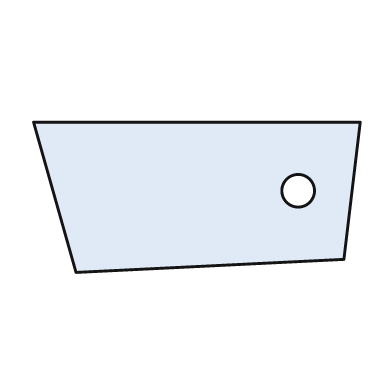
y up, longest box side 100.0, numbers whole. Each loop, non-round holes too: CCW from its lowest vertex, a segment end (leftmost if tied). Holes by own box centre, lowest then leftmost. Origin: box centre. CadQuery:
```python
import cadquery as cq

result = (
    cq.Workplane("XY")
    .moveTo(-37.0, -23.0)
    .lineTo(45.0, -19.0)
    .lineTo(50.0, 23.0)
    .lineTo(-50.0, 23.0)
    .close()
    .moveTo(31.0, 2.0)
    .circle(5.0)
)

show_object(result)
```